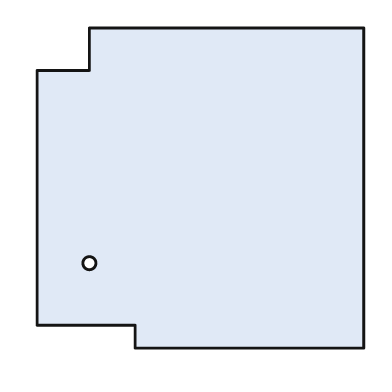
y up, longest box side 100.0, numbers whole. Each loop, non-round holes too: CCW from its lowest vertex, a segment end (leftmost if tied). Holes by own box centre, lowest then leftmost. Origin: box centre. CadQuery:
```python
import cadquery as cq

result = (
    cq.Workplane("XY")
    .moveTo(-20.0, -49.0)
    .lineTo(50.0, -49.0)
    .lineTo(50.0, 49.0)
    .lineTo(-34.0, 49.0)
    .lineTo(-34.0, 36.0)
    .lineTo(-50.0, 36.0)
    .lineTo(-50.0, -42.0)
    .lineTo(-20.0, -42.0)
    .close()
    .moveTo(-34.0, -23.0)
    .circle(2.0)
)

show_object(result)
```